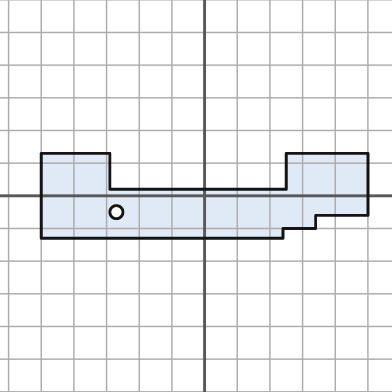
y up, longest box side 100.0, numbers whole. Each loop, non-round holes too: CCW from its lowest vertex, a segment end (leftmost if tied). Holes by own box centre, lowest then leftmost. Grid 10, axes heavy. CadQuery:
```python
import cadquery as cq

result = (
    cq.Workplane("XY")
    .moveTo(-50.0, -13.0)
    .lineTo(24.0, -13.0)
    .lineTo(24.0, -10.0)
    .lineTo(34.0, -10.0)
    .lineTo(34.0, -6.0)
    .lineTo(50.0, -6.0)
    .lineTo(50.0, 13.0)
    .lineTo(25.0, 13.0)
    .lineTo(25.0, 2.0)
    .lineTo(-29.0, 2.0)
    .lineTo(-29.0, 13.0)
    .lineTo(-50.0, 13.0)
    .close()
    .moveTo(-27.0, -5.0)
    .circle(2.0)
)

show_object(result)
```